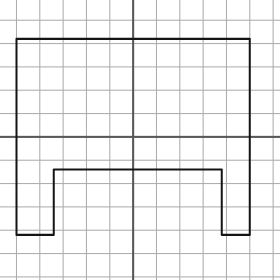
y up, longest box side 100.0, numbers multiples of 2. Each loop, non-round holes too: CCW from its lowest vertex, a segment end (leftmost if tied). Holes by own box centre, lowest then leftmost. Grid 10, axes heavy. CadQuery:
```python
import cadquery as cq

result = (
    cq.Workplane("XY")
    .moveTo(-50.0, -42.0)
    .lineTo(-34.0, -42.0)
    .lineTo(-34.0, -14.0)
    .lineTo(38.0, -14.0)
    .lineTo(38.0, -42.0)
    .lineTo(50.0, -42.0)
    .lineTo(50.0, 42.0)
    .lineTo(-50.0, 42.0)
    .close()
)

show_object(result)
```